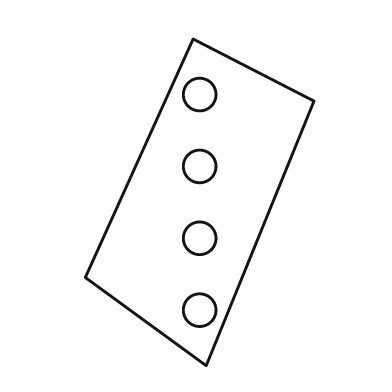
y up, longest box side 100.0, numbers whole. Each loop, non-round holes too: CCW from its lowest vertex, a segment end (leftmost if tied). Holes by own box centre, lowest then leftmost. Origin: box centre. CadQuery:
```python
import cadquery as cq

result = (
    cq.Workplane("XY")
    .moveTo(2.0, -50.0)
    .lineTo(35.0, 31.0)
    .lineTo(-2.0, 50.0)
    .lineTo(-35.0, -23.0)
    .close()
    .moveTo(0.0, -33.0)
    .circle(5.0)
    .moveTo(0.0, -11.0)
    .circle(5.0)
    .moveTo(0.0, 11.0)
    .circle(5.0)
    .moveTo(0.0, 33.0)
    .circle(5.0)
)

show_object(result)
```